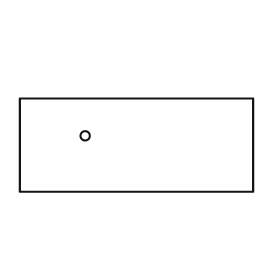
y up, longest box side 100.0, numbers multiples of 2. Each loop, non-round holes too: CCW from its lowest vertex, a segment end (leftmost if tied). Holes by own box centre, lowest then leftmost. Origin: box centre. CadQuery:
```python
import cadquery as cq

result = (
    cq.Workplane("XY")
    .moveTo(-50.0, -20.0)
    .lineTo(50.0, -20.0)
    .lineTo(50.0, 20.0)
    .lineTo(-50.0, 20.0)
    .close()
    .moveTo(-22.0, 4.0)
    .circle(2.0)
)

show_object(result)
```